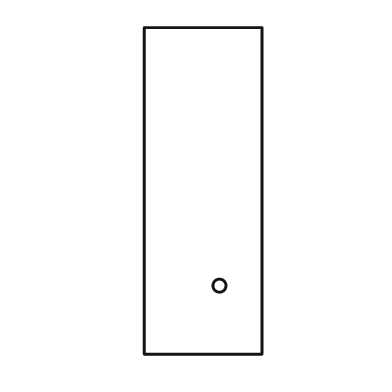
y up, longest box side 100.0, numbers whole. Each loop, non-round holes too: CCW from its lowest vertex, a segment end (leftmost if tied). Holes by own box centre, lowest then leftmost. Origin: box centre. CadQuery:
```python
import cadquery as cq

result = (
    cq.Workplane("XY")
    .moveTo(-18.0, -50.0)
    .lineTo(18.0, -50.0)
    .lineTo(18.0, 50.0)
    .lineTo(-18.0, 50.0)
    .close()
    .moveTo(5.0, -29.0)
    .circle(2.0)
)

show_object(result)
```